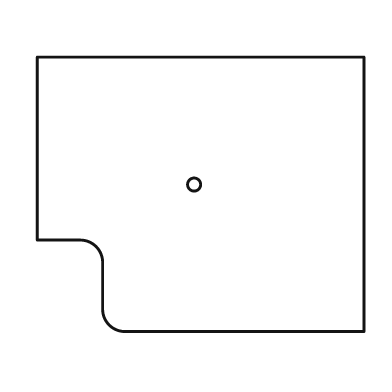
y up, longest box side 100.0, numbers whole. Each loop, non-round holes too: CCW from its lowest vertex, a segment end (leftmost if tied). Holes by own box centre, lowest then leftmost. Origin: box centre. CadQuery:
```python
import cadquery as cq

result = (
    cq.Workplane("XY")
    .moveTo(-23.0, -42.0)
    .lineTo(50.0, -42.0)
    .lineTo(50.0, 42.0)
    .lineTo(-50.0, 42.0)
    .lineTo(-50.0, -14.0)
    .lineTo(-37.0, -14.0)
    .threePointArc((-32.0, -16.0), (-30.0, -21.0))
    .lineTo(-30.0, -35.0)
    .threePointArc((-28.0, -40.0), (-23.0, -42.0))
    .close()
    .moveTo(-2.0, 3.0)
    .circle(2.0)
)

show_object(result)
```